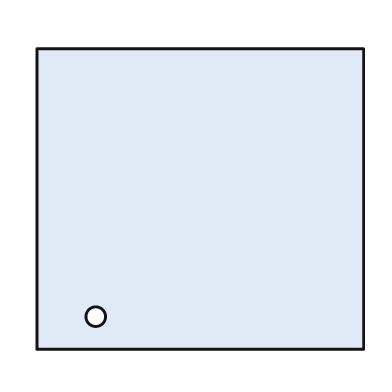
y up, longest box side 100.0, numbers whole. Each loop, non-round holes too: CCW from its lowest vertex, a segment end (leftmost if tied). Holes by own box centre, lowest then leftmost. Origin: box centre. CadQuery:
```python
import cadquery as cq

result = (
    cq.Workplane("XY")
    .moveTo(-50.0, -46.0)
    .lineTo(50.0, -46.0)
    .lineTo(50.0, 46.0)
    .lineTo(-50.0, 46.0)
    .close()
    .moveTo(-32.0, -36.0)
    .circle(3.0)
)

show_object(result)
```